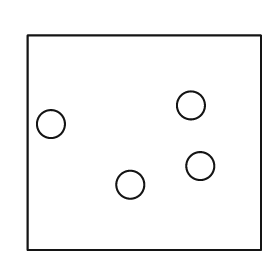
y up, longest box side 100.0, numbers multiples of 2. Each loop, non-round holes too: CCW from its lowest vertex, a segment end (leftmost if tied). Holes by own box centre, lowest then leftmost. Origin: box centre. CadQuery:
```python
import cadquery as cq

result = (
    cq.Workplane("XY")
    .moveTo(-50.0, -46.0)
    .lineTo(50.0, -46.0)
    .lineTo(50.0, 46.0)
    .lineTo(-50.0, 46.0)
    .close()
    .moveTo(-6.0, -18.0)
    .circle(6.0)
    .moveTo(24.0, -10.0)
    .circle(6.0)
    .moveTo(-40.0, 8.0)
    .circle(6.0)
    .moveTo(20.0, 16.0)
    .circle(6.0)
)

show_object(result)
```